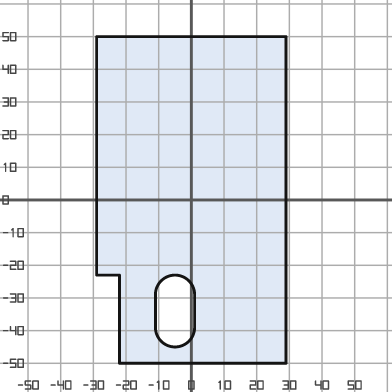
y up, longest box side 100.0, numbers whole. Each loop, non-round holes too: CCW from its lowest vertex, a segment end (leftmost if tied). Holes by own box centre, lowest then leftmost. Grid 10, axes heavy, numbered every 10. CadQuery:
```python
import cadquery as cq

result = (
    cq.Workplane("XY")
    .moveTo(-22.0, -50.0)
    .lineTo(29.0, -50.0)
    .lineTo(29.0, 50.0)
    .lineTo(-29.0, 50.0)
    .lineTo(-29.0, -23.0)
    .lineTo(-22.0, -23.0)
    .close()
    .moveTo(-11.0, -39.0)
    .threePointArc((-5.0, -45.0), (1.0, -39.0))
    .lineTo(1.0, -29.0)
    .threePointArc((-5.0, -23.0), (-11.0, -29.0))
    .close()
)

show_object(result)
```